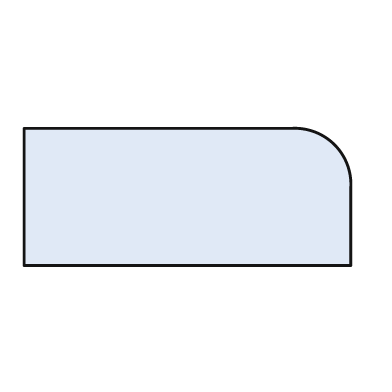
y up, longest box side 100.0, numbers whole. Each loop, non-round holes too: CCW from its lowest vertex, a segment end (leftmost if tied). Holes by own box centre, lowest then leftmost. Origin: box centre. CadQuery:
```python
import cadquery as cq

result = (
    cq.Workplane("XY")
    .moveTo(-50.0, -21.0)
    .lineTo(50.0, -21.0)
    .lineTo(50.0, 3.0)
    .threePointArc((45.0, 16.0), (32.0, 21.0))
    .lineTo(-50.0, 21.0)
    .close()
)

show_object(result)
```